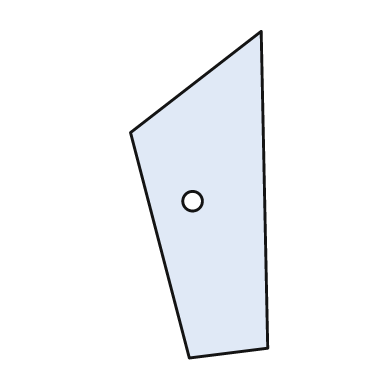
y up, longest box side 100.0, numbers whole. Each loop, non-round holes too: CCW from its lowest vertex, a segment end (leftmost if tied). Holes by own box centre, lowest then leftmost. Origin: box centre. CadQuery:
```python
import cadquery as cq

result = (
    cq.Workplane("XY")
    .moveTo(-3.0, -50.0)
    .lineTo(21.0, -47.0)
    .lineTo(19.0, 50.0)
    .lineTo(-21.0, 19.0)
    .close()
    .moveTo(-2.0, -2.0)
    .circle(3.0)
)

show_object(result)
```